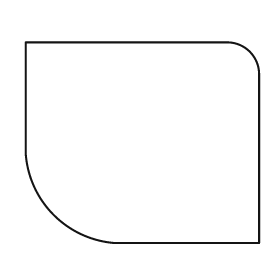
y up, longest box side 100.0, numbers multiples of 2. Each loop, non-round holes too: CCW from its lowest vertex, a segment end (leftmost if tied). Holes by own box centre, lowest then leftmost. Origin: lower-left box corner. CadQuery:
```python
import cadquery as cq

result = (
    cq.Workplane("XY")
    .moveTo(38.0, 0.0)
    .lineTo(100.0, 0.0)
    .lineTo(100.0, 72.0)
    .threePointArc((96.0, 82.0), (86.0, 86.0))
    .lineTo(0.0, 86.0)
    .lineTo(0.0, 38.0)
    .threePointArc((12.0, 12.0), (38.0, 0.0))
    .close()
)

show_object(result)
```